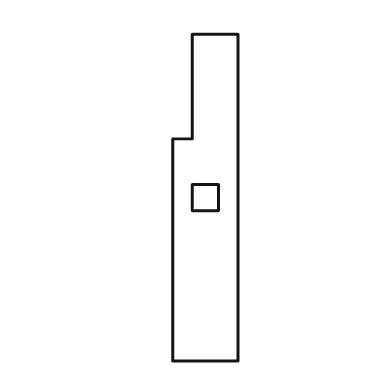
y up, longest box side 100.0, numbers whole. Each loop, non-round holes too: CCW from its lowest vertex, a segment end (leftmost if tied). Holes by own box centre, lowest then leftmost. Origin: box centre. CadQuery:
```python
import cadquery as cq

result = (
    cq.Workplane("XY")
    .moveTo(-10.0, -50.0)
    .lineTo(10.0, -50.0)
    .lineTo(10.0, 50.0)
    .lineTo(-4.0, 50.0)
    .lineTo(-4.0, 18.0)
    .lineTo(-10.0, 18.0)
    .close()
    .moveTo(-4.0, -4.0)
    .lineTo(4.0, -4.0)
    .lineTo(4.0, 4.0)
    .lineTo(-4.0, 4.0)
    .close()
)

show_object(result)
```